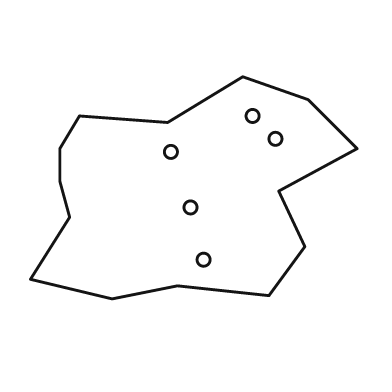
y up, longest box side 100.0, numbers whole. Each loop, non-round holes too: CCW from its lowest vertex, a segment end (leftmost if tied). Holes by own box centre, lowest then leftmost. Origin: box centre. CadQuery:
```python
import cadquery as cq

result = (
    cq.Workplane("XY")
    .moveTo(-25.0, -34.0)
    .lineTo(-5.0, -30.0)
    .lineTo(23.0, -33.0)
    .lineTo(34.0, -18.0)
    .lineTo(26.0, -1.0)
    .lineTo(50.0, 12.0)
    .lineTo(35.0, 27.0)
    .lineTo(15.0, 34.0)
    .lineTo(-8.0, 20.0)
    .lineTo(-35.0, 22.0)
    .lineTo(-41.0, 12.0)
    .lineTo(-41.0, 2.0)
    .lineTo(-38.0, -9.0)
    .lineTo(-50.0, -28.0)
    .close()
    .moveTo(3.0, -22.0)
    .circle(2.0)
    .moveTo(-1.0, -6.0)
    .circle(2.0)
    .moveTo(-7.0, 11.0)
    .circle(2.0)
    .moveTo(25.0, 15.0)
    .circle(2.0)
    .moveTo(18.0, 22.0)
    .circle(2.0)
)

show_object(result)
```